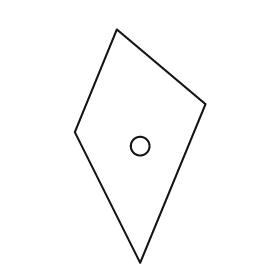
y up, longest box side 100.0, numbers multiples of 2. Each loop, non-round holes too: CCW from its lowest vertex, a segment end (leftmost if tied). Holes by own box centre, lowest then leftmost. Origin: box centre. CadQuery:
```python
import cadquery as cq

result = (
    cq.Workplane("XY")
    .moveTo(0.0, -50.0)
    .lineTo(28.0, 18.0)
    .lineTo(-10.0, 50.0)
    .lineTo(-28.0, 6.0)
    .close()
    .moveTo(0.0, 0.0)
    .circle(4.0)
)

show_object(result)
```